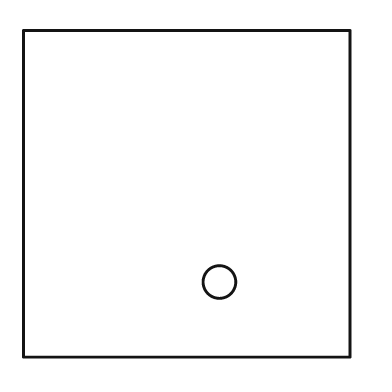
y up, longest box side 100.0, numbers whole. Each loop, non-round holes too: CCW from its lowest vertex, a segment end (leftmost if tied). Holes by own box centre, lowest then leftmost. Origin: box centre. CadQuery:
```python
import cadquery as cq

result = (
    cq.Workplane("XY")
    .moveTo(-50.0, -50.0)
    .lineTo(50.0, -50.0)
    .lineTo(50.0, 50.0)
    .lineTo(-50.0, 50.0)
    .close()
    .moveTo(10.0, -27.0)
    .circle(5.0)
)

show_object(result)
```